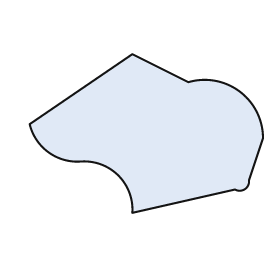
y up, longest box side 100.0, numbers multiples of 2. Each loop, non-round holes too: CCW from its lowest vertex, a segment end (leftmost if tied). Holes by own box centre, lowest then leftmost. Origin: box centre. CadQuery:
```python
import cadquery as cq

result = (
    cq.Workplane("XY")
    .moveTo(-6.0, -34.0)
    .lineTo(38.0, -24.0)
    .threePointArc((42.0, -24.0), (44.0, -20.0))
    .lineTo(50.0, -2.0)
    .threePointArc((40.0, 18.0), (18.0, 22.0))
    .lineTo(-6.0, 34.0)
    .lineTo(-50.0, 4.0)
    .threePointArc((-42.0, -8.0), (-28.0, -12.0))
    .threePointArc((-12.0, -18.0), (-6.0, -34.0))
    .close()
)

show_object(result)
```